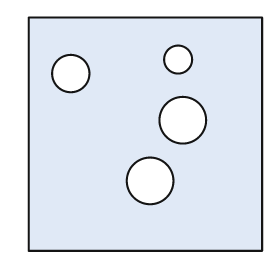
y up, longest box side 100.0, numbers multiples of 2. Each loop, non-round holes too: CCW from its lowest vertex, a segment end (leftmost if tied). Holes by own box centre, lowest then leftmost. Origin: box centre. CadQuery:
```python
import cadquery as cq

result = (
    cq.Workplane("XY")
    .moveTo(-50.0, -50.0)
    .lineTo(50.0, -50.0)
    .lineTo(50.0, 50.0)
    .lineTo(-50.0, 50.0)
    .close()
    .moveTo(2.0, -20.0)
    .circle(10.0)
    .moveTo(16.0, 6.0)
    .circle(10.0)
    .moveTo(-32.0, 26.0)
    .circle(8.0)
    .moveTo(14.0, 32.0)
    .circle(6.0)
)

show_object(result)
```